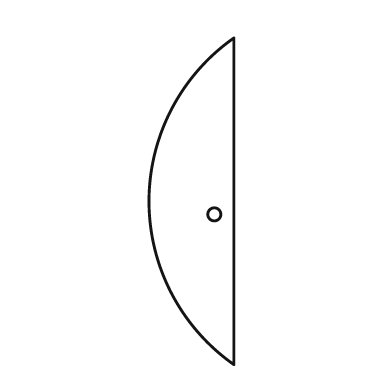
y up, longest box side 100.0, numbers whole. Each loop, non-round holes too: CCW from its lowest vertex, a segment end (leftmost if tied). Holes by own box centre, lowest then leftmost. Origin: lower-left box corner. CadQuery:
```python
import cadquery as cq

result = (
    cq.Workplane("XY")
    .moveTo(26.0, 0.0)
    .lineTo(26.0, 100.0)
    .threePointArc((0.0, 50.0), (26.0, 0.0))
    .close()
    .moveTo(20.0, 46.0)
    .circle(2.0)
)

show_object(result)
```